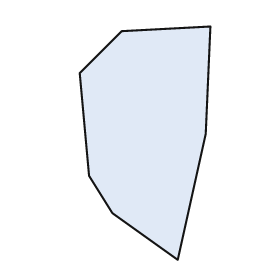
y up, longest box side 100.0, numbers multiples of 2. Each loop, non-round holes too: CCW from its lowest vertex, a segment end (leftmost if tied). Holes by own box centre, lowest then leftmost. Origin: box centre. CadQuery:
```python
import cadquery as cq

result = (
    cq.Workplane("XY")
    .moveTo(14.0, -50.0)
    .lineTo(26.0, 4.0)
    .lineTo(28.0, 50.0)
    .lineTo(-10.0, 48.0)
    .lineTo(-28.0, 30.0)
    .lineTo(-24.0, -14.0)
    .lineTo(-14.0, -30.0)
    .close()
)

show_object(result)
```